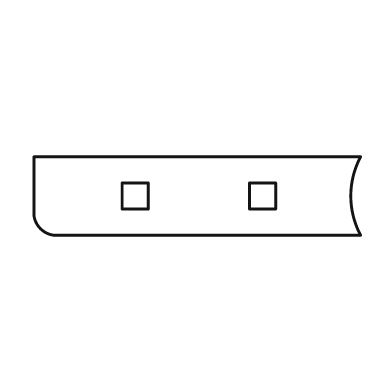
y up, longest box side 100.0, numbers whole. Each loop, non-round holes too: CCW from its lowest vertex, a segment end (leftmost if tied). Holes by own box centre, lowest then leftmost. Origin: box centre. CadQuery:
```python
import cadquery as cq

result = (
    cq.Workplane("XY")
    .moveTo(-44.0, -12.0)
    .lineTo(50.0, -12.0)
    .threePointArc((47.0, 0.0), (50.0, 12.0))
    .lineTo(-50.0, 12.0)
    .lineTo(-50.0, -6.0)
    .threePointArc((-48.0, -10.0), (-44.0, -12.0))
    .close()
    .moveTo(-23.0, -4.0)
    .lineTo(-15.0, -4.0)
    .lineTo(-15.0, 4.0)
    .lineTo(-23.0, 4.0)
    .close()
    .moveTo(16.0, -4.0)
    .lineTo(24.0, -4.0)
    .lineTo(24.0, 4.0)
    .lineTo(16.0, 4.0)
    .close()
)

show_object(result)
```